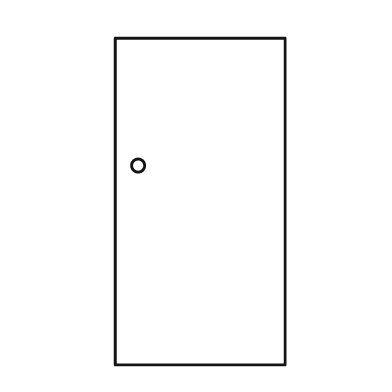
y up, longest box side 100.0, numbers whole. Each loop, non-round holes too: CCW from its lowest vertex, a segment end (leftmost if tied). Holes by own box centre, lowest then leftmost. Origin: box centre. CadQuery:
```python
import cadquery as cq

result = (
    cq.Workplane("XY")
    .moveTo(-26.0, -50.0)
    .lineTo(26.0, -50.0)
    .lineTo(26.0, 50.0)
    .lineTo(-26.0, 50.0)
    .close()
    .moveTo(-19.0, 11.0)
    .circle(2.0)
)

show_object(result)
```